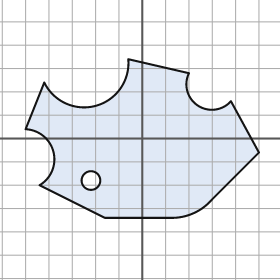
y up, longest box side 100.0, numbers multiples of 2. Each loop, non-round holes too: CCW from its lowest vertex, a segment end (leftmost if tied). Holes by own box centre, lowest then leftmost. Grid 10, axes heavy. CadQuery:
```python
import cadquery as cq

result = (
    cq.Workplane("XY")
    .moveTo(-16.0, -34.0)
    .lineTo(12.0, -34.0)
    .threePointArc((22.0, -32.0), (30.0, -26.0))
    .lineTo(50.0, -6.0)
    .lineTo(38.0, 16.0)
    .threePointArc((24.0, 14.0), (20.0, 28.0))
    .lineTo(-6.0, 34.0)
    .threePointArc((-20.0, 14.0), (-42.0, 24.0))
    .lineTo(-50.0, 4.0)
    .threePointArc((-38.0, -6.0), (-44.0, -20.0))
    .close()
    .moveTo(-22.0, -18.0)
    .circle(4.0)
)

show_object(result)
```